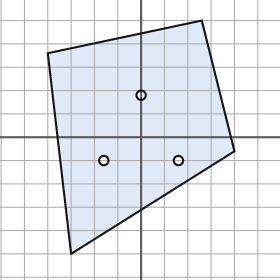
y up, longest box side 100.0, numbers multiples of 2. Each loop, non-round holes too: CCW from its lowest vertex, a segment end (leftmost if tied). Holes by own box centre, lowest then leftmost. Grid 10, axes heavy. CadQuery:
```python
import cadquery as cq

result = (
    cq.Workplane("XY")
    .moveTo(-30.0, -50.0)
    .lineTo(40.0, -6.0)
    .lineTo(26.0, 50.0)
    .lineTo(-40.0, 36.0)
    .close()
    .moveTo(-16.0, -10.0)
    .circle(2.0)
    .moveTo(16.0, -10.0)
    .circle(2.0)
    .moveTo(0.0, 18.0)
    .circle(2.0)
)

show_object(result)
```